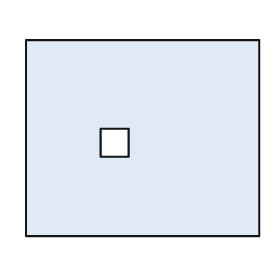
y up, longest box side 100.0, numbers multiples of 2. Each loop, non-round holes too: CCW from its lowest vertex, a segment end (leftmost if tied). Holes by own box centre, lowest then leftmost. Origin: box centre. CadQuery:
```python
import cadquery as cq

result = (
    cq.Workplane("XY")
    .moveTo(-50.0, -42.0)
    .lineTo(50.0, -42.0)
    .lineTo(50.0, 42.0)
    .lineTo(-50.0, 42.0)
    .close()
    .moveTo(-18.0, -8.0)
    .lineTo(-6.0, -8.0)
    .lineTo(-6.0, 4.0)
    .lineTo(-18.0, 4.0)
    .close()
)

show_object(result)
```